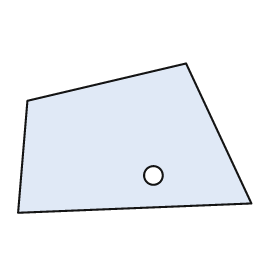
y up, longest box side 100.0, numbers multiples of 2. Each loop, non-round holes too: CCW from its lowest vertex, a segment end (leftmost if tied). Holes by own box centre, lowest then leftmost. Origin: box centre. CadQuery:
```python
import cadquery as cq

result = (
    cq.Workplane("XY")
    .moveTo(-50.0, -32.0)
    .lineTo(50.0, -28.0)
    .lineTo(22.0, 32.0)
    .lineTo(-46.0, 16.0)
    .close()
    .moveTo(8.0, -16.0)
    .circle(4.0)
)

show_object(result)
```